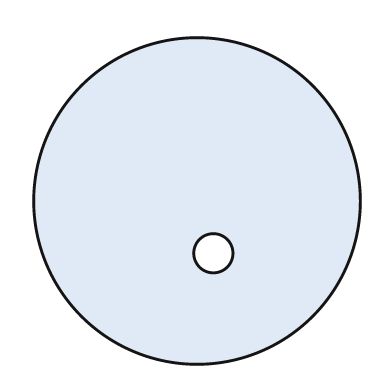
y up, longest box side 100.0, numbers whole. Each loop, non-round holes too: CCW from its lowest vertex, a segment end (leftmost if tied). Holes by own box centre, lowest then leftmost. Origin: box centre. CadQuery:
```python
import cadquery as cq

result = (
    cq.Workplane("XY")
    .moveTo(0.0, 0.0)
    .circle(50.0)
    .moveTo(5.0, -16.0)
    .circle(6.0)
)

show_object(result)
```